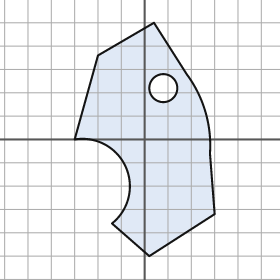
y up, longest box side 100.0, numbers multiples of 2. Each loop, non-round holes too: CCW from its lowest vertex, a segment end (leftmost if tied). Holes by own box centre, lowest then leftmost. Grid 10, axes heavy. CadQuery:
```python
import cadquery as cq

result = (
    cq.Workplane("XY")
    .moveTo(2.0, -50.0)
    .lineTo(30.0, -32.0)
    .lineTo(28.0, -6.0)
    .threePointArc((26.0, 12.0), (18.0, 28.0))
    .lineTo(4.0, 50.0)
    .lineTo(-20.0, 36.0)
    .lineTo(-30.0, 0.0)
    .threePointArc((-8.0, -12.0), (-14.0, -36.0))
    .close()
    .moveTo(8.0, 22.0)
    .circle(6.0)
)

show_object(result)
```